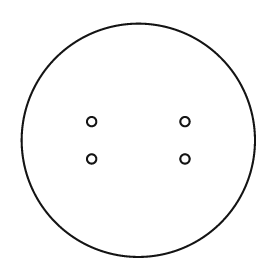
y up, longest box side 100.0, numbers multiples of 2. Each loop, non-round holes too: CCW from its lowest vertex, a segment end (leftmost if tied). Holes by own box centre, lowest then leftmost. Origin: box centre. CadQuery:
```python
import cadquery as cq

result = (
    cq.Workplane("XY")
    .moveTo(0.0, 0.0)
    .circle(50.0)
    .moveTo(-20.0, -8.0)
    .circle(2.0)
    .moveTo(20.0, -8.0)
    .circle(2.0)
    .moveTo(-20.0, 8.0)
    .circle(2.0)
    .moveTo(20.0, 8.0)
    .circle(2.0)
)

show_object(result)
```